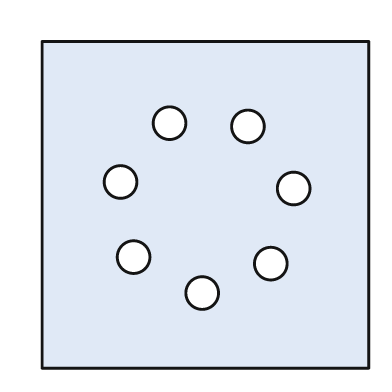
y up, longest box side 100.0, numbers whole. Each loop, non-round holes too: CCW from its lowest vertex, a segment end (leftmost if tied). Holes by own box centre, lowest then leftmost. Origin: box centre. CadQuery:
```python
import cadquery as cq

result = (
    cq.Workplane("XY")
    .moveTo(-50.0, -50.0)
    .lineTo(50.0, -50.0)
    .lineTo(50.0, 50.0)
    .lineTo(-50.0, 50.0)
    .close()
    .moveTo(-1.0, -27.0)
    .circle(5.0)
    .moveTo(20.0, -18.0)
    .circle(5.0)
    .moveTo(-22.0, -16.0)
    .circle(5.0)
    .moveTo(27.0, 5.0)
    .circle(5.0)
    .moveTo(-26.0, 7.0)
    .circle(5.0)
    .moveTo(13.0, 24.0)
    .circle(5.0)
    .moveTo(-11.0, 25.0)
    .circle(5.0)
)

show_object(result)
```